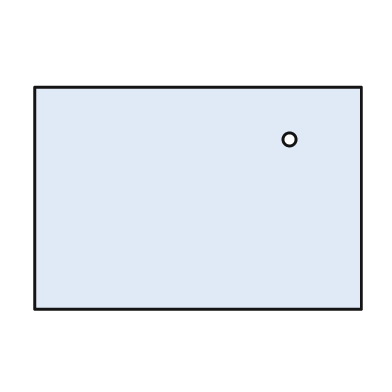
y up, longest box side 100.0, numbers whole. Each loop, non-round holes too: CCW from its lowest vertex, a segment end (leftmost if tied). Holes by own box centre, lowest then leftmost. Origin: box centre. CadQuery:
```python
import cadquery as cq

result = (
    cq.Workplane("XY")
    .moveTo(-50.0, -34.0)
    .lineTo(50.0, -34.0)
    .lineTo(50.0, 34.0)
    .lineTo(-50.0, 34.0)
    .close()
    .moveTo(28.0, 18.0)
    .circle(2.0)
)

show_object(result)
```